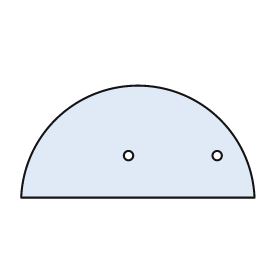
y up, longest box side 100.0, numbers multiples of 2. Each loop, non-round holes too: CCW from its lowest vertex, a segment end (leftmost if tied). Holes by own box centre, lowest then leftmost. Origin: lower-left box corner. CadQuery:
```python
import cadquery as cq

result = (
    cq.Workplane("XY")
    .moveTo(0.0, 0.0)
    .lineTo(100.0, 0.0)
    .threePointArc((50.0, 48.0), (0.0, 0.0))
    .close()
    .moveTo(46.0, 18.0)
    .circle(2.0)
    .moveTo(84.0, 18.0)
    .circle(2.0)
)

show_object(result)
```